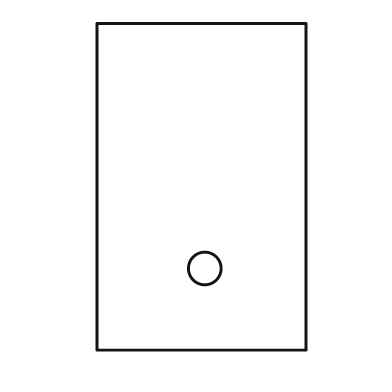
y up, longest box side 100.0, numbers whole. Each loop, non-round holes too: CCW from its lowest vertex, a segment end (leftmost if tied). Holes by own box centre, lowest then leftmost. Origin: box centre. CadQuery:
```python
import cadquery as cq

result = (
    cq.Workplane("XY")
    .moveTo(-32.0, -50.0)
    .lineTo(32.0, -50.0)
    .lineTo(32.0, 50.0)
    .lineTo(-32.0, 50.0)
    .close()
    .moveTo(1.0, -25.0)
    .circle(5.0)
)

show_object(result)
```